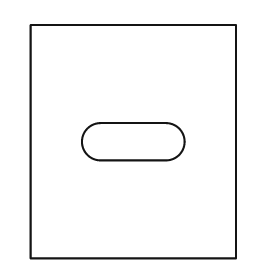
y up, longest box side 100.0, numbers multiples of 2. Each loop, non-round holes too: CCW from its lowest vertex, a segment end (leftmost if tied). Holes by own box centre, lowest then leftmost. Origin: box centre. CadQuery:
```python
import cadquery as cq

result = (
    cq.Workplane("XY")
    .moveTo(-44.0, -50.0)
    .lineTo(44.0, -50.0)
    .lineTo(44.0, 50.0)
    .lineTo(-44.0, 50.0)
    .close()
    .moveTo(-14.0, -8.0)
    .lineTo(14.0, -8.0)
    .threePointArc((22.0, 0.0), (14.0, 8.0))
    .lineTo(-14.0, 8.0)
    .threePointArc((-22.0, 0.0), (-14.0, -8.0))
    .close()
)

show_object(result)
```